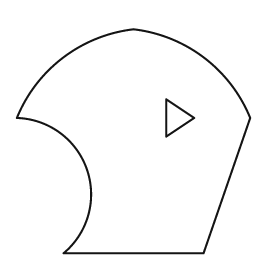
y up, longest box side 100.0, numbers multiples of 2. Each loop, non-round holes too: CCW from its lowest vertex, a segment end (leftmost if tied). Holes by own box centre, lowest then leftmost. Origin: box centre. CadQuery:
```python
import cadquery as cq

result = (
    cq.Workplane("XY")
    .moveTo(-30.0, -48.0)
    .lineTo(30.0, -48.0)
    .lineTo(50.0, 10.0)
    .threePointArc((30.0, 36.0), (0.0, 48.0))
    .threePointArc((-30.0, 36.0), (-50.0, 10.0))
    .threePointArc((-20.0, -12.0), (-30.0, -48.0))
    .close()
    .moveTo(14.0, 2.0)
    .lineTo(26.0, 10.0)
    .lineTo(14.0, 18.0)
    .close()
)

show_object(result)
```